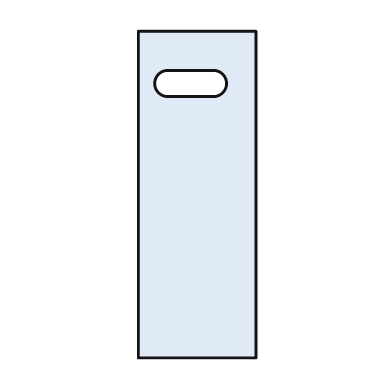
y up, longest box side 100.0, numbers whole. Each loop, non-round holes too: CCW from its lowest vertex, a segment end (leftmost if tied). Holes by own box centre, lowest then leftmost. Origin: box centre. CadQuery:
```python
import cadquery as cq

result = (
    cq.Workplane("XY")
    .moveTo(-18.0, -50.0)
    .lineTo(18.0, -50.0)
    .lineTo(18.0, 50.0)
    .lineTo(-18.0, 50.0)
    .close()
    .moveTo(-9.0, 30.0)
    .lineTo(5.0, 30.0)
    .threePointArc((9.0, 34.0), (5.0, 38.0))
    .lineTo(-9.0, 38.0)
    .threePointArc((-13.0, 34.0), (-9.0, 30.0))
    .close()
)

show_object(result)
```